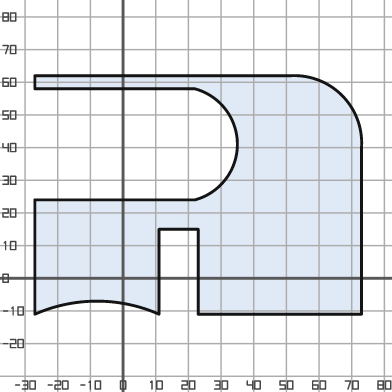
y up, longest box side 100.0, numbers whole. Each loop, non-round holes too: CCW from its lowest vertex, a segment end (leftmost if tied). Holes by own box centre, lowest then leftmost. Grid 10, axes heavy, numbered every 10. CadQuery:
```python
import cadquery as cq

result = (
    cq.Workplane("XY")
    .moveTo(-27.0, -11.0)
    .threePointArc((-8.0, -7.0), (11.0, -11.0))
    .lineTo(11.0, 15.0)
    .lineTo(23.0, 15.0)
    .lineTo(23.0, -11.0)
    .lineTo(73.0, -11.0)
    .lineTo(73.0, 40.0)
    .threePointArc((67.0, 56.0), (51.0, 62.0))
    .lineTo(-27.0, 62.0)
    .lineTo(-27.0, 58.0)
    .lineTo(22.0, 58.0)
    .threePointArc((35.0, 41.0), (22.0, 24.0))
    .lineTo(-27.0, 24.0)
    .close()
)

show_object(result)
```